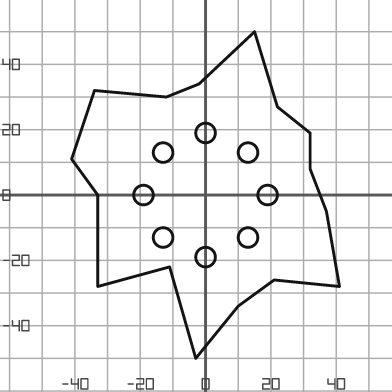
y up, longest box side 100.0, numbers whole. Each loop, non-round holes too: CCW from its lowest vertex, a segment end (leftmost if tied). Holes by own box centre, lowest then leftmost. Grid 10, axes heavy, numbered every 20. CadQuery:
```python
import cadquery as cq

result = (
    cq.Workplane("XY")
    .moveTo(-3.0, -50.0)
    .lineTo(10.0, -34.0)
    .lineTo(21.0, -26.0)
    .lineTo(41.0, -28.0)
    .lineTo(37.0, -5.0)
    .lineTo(32.0, 8.0)
    .lineTo(32.0, 19.0)
    .lineTo(22.0, 27.0)
    .lineTo(15.0, 50.0)
    .lineTo(-2.0, 34.0)
    .lineTo(-12.0, 30.0)
    .lineTo(-34.0, 32.0)
    .lineTo(-41.0, 11.0)
    .lineTo(-33.0, 0.0)
    .lineTo(-33.0, -28.0)
    .lineTo(-11.0, -22.0)
    .close()
    .moveTo(0.0, -19.0)
    .circle(3.0)
    .moveTo(-13.0, -13.0)
    .circle(3.0)
    .moveTo(13.0, -13.0)
    .circle(3.0)
    .moveTo(-19.0, 0.0)
    .circle(3.0)
    .moveTo(19.0, 0.0)
    .circle(3.0)
    .moveTo(-13.0, 13.0)
    .circle(3.0)
    .moveTo(13.0, 13.0)
    .circle(3.0)
    .moveTo(0.0, 19.0)
    .circle(3.0)
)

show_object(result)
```